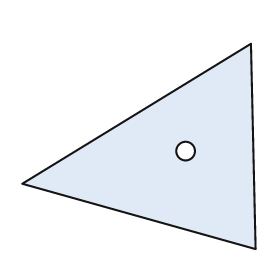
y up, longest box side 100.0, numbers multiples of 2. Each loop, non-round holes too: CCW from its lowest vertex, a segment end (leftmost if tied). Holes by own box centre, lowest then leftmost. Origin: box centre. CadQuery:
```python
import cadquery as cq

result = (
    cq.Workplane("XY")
    .moveTo(50.0, -44.0)
    .lineTo(48.0, 44.0)
    .lineTo(-50.0, -16.0)
    .close()
    .moveTo(20.0, -2.0)
    .circle(4.0)
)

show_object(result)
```